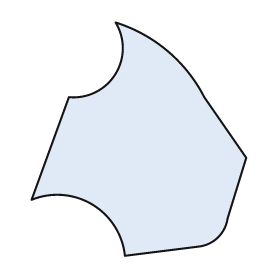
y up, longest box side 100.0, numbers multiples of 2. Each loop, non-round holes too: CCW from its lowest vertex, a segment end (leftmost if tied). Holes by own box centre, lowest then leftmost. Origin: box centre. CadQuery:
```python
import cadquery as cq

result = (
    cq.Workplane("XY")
    .moveTo(-6.0, -50.0)
    .lineTo(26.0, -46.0)
    .threePointArc((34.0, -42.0), (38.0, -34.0))
    .lineTo(46.0, -8.0)
    .lineTo(28.0, 18.0)
    .threePointArc((12.0, 38.0), (-10.0, 50.0))
    .threePointArc((-10.0, 28.0), (-30.0, 18.0))
    .lineTo(-46.0, -26.0)
    .threePointArc((-20.0, -28.0), (-6.0, -50.0))
    .close()
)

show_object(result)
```